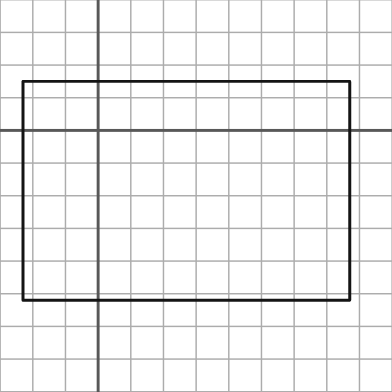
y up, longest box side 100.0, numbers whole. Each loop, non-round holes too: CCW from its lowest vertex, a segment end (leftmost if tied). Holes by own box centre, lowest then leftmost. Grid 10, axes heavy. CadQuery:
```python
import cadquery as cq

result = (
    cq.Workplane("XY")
    .moveTo(-23.0, -52.0)
    .lineTo(77.0, -52.0)
    .lineTo(77.0, 15.0)
    .lineTo(-23.0, 15.0)
    .close()
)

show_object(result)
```